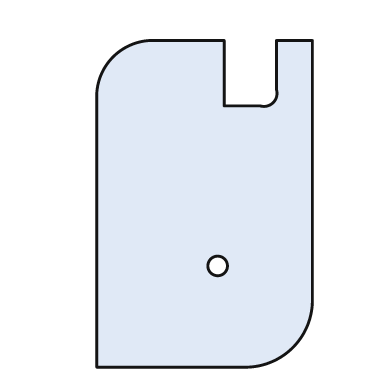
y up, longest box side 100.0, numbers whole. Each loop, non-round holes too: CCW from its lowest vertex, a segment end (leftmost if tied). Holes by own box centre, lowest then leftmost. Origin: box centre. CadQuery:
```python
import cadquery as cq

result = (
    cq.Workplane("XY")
    .moveTo(-33.0, -50.0)
    .lineTo(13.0, -50.0)
    .threePointArc((27.0, -44.0), (33.0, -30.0))
    .lineTo(33.0, 50.0)
    .lineTo(22.0, 50.0)
    .lineTo(22.0, 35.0)
    .threePointArc((21.0, 31.0), (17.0, 30.0))
    .lineTo(6.0, 30.0)
    .lineTo(6.0, 50.0)
    .lineTo(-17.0, 50.0)
    .threePointArc((-28.0, 45.0), (-33.0, 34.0))
    .close()
    .moveTo(4.0, -19.0)
    .circle(3.0)
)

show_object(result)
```